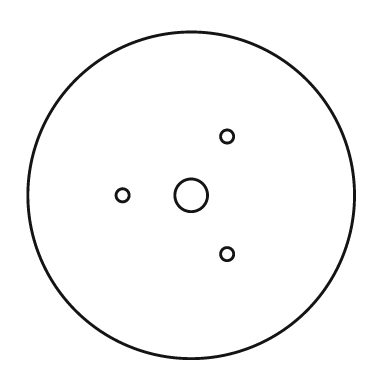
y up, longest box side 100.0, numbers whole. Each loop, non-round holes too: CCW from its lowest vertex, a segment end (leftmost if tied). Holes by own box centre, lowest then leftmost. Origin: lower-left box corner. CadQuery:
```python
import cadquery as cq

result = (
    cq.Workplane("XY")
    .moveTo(50.0, 50.0)
    .circle(50.0)
    .moveTo(61.0, 32.0)
    .circle(2.0)
    .moveTo(29.0, 50.0)
    .circle(2.0)
    .moveTo(50.0, 50.0)
    .circle(5.0)
    .moveTo(61.0, 68.0)
    .circle(2.0)
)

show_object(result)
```